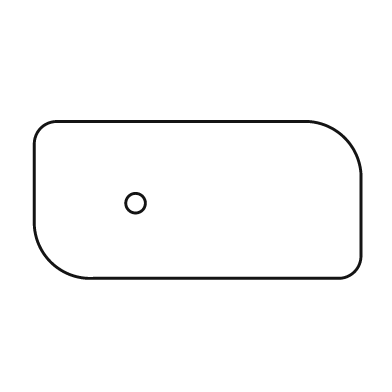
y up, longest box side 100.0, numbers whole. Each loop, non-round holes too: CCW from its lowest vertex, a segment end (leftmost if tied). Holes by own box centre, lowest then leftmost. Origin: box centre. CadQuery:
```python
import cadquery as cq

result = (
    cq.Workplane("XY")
    .moveTo(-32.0, -24.0)
    .lineTo(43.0, -24.0)
    .threePointArc((48.0, -22.0), (50.0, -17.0))
    .lineTo(50.0, 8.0)
    .threePointArc((45.0, 19.0), (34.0, 24.0))
    .lineTo(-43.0, 24.0)
    .threePointArc((-48.0, 22.0), (-50.0, 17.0))
    .lineTo(-50.0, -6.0)
    .threePointArc((-45.0, -19.0), (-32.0, -24.0))
    .close()
    .moveTo(-19.0, -1.0)
    .circle(3.0)
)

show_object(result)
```